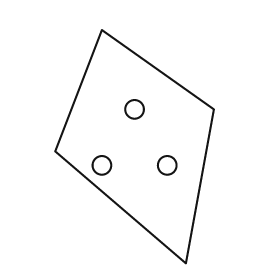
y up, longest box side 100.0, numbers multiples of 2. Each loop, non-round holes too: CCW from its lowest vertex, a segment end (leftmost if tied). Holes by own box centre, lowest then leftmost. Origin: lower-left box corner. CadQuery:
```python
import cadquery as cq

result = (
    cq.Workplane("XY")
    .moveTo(56.0, 0.0)
    .lineTo(68.0, 66.0)
    .lineTo(20.0, 100.0)
    .lineTo(0.0, 48.0)
    .close()
    .moveTo(20.0, 42.0)
    .circle(4.0)
    .moveTo(48.0, 42.0)
    .circle(4.0)
    .moveTo(34.0, 66.0)
    .circle(4.0)
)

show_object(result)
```